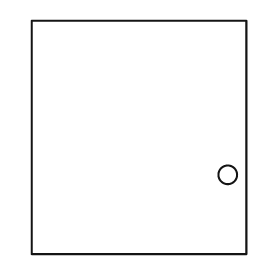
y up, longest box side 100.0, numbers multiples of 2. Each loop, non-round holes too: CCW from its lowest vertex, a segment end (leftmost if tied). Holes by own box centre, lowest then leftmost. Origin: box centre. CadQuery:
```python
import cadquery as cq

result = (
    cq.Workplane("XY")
    .moveTo(-46.0, -50.0)
    .lineTo(46.0, -50.0)
    .lineTo(46.0, 50.0)
    .lineTo(-46.0, 50.0)
    .close()
    .moveTo(38.0, -16.0)
    .circle(4.0)
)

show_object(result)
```